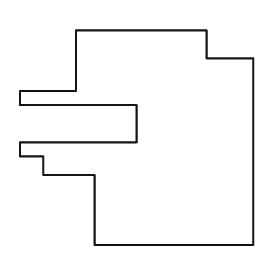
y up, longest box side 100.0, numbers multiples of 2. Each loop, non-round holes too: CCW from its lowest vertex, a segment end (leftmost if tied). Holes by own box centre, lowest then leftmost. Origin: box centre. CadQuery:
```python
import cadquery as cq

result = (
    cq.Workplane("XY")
    .moveTo(-18.0, -46.0)
    .lineTo(50.0, -46.0)
    .lineTo(50.0, 34.0)
    .lineTo(30.0, 34.0)
    .lineTo(30.0, 46.0)
    .lineTo(-26.0, 46.0)
    .lineTo(-26.0, 20.0)
    .lineTo(-50.0, 20.0)
    .lineTo(-50.0, 14.0)
    .lineTo(0.0, 14.0)
    .lineTo(0.0, -2.0)
    .lineTo(-50.0, -2.0)
    .lineTo(-50.0, -8.0)
    .lineTo(-40.0, -8.0)
    .lineTo(-40.0, -16.0)
    .lineTo(-18.0, -16.0)
    .close()
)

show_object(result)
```